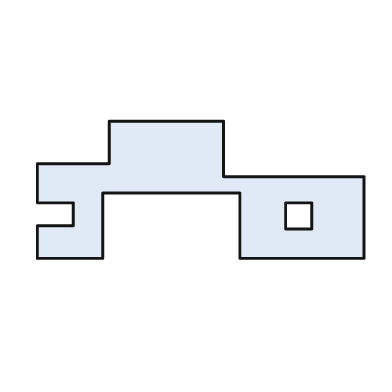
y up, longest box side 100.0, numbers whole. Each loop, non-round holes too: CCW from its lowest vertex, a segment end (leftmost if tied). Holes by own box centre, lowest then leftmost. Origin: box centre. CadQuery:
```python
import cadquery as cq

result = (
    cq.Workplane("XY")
    .moveTo(-50.0, -21.0)
    .lineTo(-30.0, -21.0)
    .lineTo(-30.0, -1.0)
    .lineTo(12.0, -1.0)
    .lineTo(12.0, -21.0)
    .lineTo(50.0, -21.0)
    .lineTo(50.0, 4.0)
    .lineTo(7.0, 4.0)
    .lineTo(7.0, 21.0)
    .lineTo(-28.0, 21.0)
    .lineTo(-28.0, 8.0)
    .lineTo(-50.0, 8.0)
    .lineTo(-50.0, -4.0)
    .lineTo(-39.0, -4.0)
    .lineTo(-39.0, -11.0)
    .lineTo(-50.0, -11.0)
    .close()
    .moveTo(26.0, -12.0)
    .lineTo(34.0, -12.0)
    .lineTo(34.0, -4.0)
    .lineTo(26.0, -4.0)
    .close()
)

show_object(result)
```